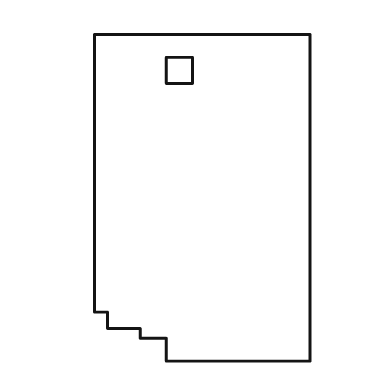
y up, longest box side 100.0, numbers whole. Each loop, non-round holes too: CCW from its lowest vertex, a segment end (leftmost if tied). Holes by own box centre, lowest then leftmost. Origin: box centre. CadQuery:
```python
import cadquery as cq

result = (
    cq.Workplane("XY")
    .moveTo(-11.0, -50.0)
    .lineTo(33.0, -50.0)
    .lineTo(33.0, 50.0)
    .lineTo(-33.0, 50.0)
    .lineTo(-33.0, -35.0)
    .lineTo(-29.0, -35.0)
    .lineTo(-29.0, -40.0)
    .lineTo(-19.0, -40.0)
    .lineTo(-19.0, -43.0)
    .lineTo(-11.0, -43.0)
    .close()
    .moveTo(-11.0, 35.0)
    .lineTo(-3.0, 35.0)
    .lineTo(-3.0, 43.0)
    .lineTo(-11.0, 43.0)
    .close()
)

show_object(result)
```